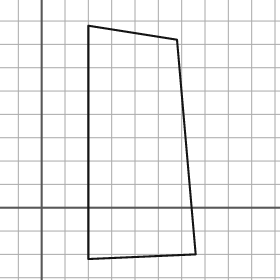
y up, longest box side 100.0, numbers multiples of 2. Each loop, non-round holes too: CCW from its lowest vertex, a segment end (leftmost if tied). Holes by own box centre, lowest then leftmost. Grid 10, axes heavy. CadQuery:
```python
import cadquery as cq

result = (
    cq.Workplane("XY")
    .moveTo(20.0, -22.0)
    .lineTo(66.0, -20.0)
    .lineTo(58.0, 72.0)
    .lineTo(20.0, 78.0)
    .close()
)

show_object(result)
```